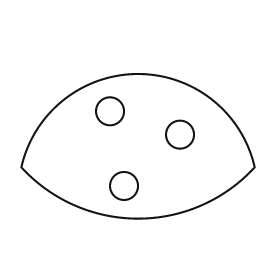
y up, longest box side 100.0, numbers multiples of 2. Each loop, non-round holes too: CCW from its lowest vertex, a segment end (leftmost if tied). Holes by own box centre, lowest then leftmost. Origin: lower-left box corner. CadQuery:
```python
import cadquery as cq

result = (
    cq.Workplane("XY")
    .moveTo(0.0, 22.0)
    .threePointArc((50.0, 0.0), (100.0, 22.0))
    .threePointArc((50.0, 62.0), (0.0, 22.0))
    .close()
    .moveTo(44.0, 14.0)
    .circle(6.0)
    .moveTo(68.0, 36.0)
    .circle(6.0)
    .moveTo(38.0, 46.0)
    .circle(6.0)
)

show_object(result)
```